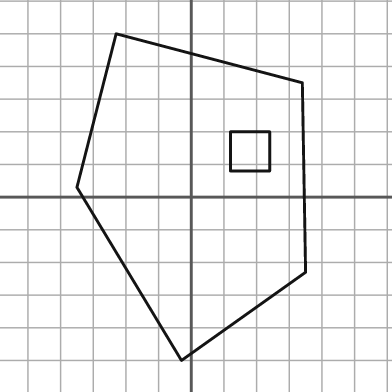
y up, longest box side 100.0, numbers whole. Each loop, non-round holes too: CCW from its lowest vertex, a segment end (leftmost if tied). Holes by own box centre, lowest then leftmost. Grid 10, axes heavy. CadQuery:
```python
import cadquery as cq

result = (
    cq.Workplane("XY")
    .moveTo(-3.0, -50.0)
    .lineTo(35.0, -23.0)
    .lineTo(34.0, 35.0)
    .lineTo(-23.0, 50.0)
    .lineTo(-35.0, 3.0)
    .close()
    .moveTo(12.0, 8.0)
    .lineTo(24.0, 8.0)
    .lineTo(24.0, 20.0)
    .lineTo(12.0, 20.0)
    .close()
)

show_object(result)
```